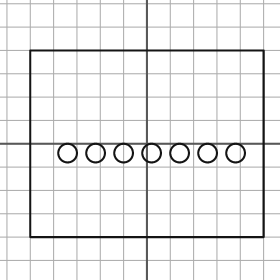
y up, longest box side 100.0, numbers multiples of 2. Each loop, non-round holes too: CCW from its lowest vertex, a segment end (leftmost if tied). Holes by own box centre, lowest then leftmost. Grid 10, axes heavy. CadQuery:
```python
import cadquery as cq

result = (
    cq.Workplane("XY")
    .moveTo(-50.0, -40.0)
    .lineTo(50.0, -40.0)
    .lineTo(50.0, 40.0)
    .lineTo(-50.0, 40.0)
    .close()
    .moveTo(-34.0, -4.0)
    .circle(4.0)
    .moveTo(-22.0, -4.0)
    .circle(4.0)
    .moveTo(-10.0, -4.0)
    .circle(4.0)
    .moveTo(2.0, -4.0)
    .circle(4.0)
    .moveTo(14.0, -4.0)
    .circle(4.0)
    .moveTo(26.0, -4.0)
    .circle(4.0)
    .moveTo(38.0, -4.0)
    .circle(4.0)
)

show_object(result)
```